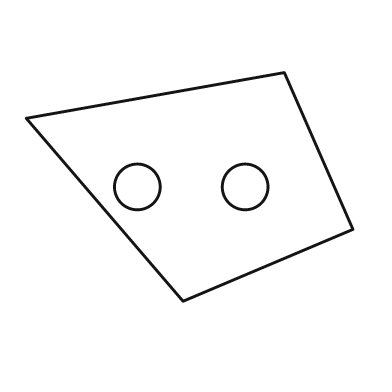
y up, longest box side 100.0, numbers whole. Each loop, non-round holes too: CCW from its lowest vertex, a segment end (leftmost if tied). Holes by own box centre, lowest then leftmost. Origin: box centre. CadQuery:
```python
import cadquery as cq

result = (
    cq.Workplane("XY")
    .moveTo(-2.0, -35.0)
    .lineTo(50.0, -13.0)
    .lineTo(29.0, 35.0)
    .lineTo(-50.0, 21.0)
    .close()
    .moveTo(-16.0, 0.0)
    .circle(7.0)
    .moveTo(17.0, 0.0)
    .circle(7.0)
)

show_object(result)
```